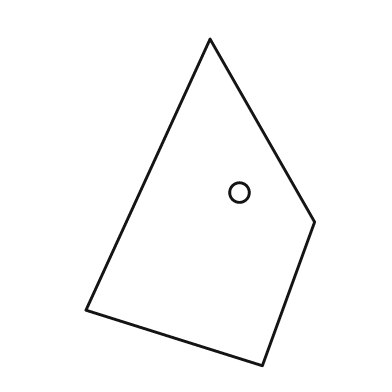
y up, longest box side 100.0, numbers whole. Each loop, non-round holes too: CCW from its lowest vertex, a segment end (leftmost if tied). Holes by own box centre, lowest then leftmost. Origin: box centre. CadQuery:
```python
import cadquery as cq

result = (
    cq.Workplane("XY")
    .moveTo(19.0, -50.0)
    .lineTo(35.0, -6.0)
    .lineTo(3.0, 50.0)
    .lineTo(-35.0, -33.0)
    .close()
    .moveTo(12.0, 3.0)
    .circle(3.0)
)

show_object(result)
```